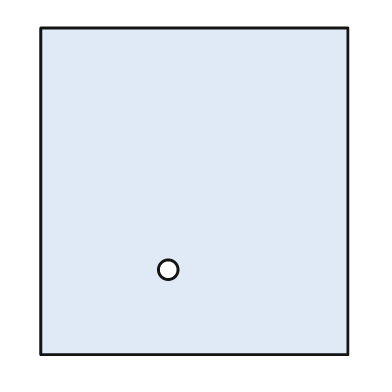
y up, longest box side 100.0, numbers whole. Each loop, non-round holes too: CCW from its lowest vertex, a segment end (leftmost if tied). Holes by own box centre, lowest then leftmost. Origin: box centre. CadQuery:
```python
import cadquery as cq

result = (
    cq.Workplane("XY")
    .moveTo(-47.0, -50.0)
    .lineTo(47.0, -50.0)
    .lineTo(47.0, 50.0)
    .lineTo(-47.0, 50.0)
    .close()
    .moveTo(-8.0, -24.0)
    .circle(3.0)
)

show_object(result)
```